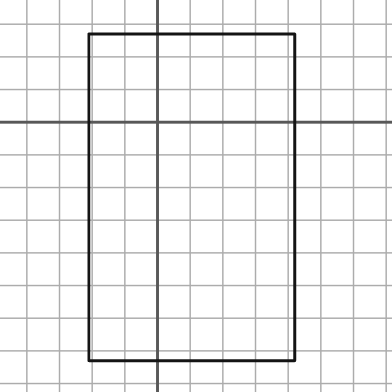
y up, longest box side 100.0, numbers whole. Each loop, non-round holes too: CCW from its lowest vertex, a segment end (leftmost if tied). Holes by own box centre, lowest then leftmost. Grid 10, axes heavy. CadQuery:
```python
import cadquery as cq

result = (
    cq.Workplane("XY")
    .moveTo(-21.0, -73.0)
    .lineTo(42.0, -73.0)
    .lineTo(42.0, 27.0)
    .lineTo(-21.0, 27.0)
    .close()
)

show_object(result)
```